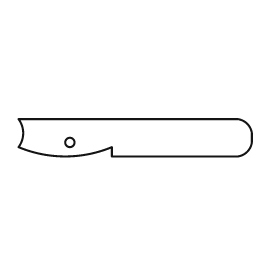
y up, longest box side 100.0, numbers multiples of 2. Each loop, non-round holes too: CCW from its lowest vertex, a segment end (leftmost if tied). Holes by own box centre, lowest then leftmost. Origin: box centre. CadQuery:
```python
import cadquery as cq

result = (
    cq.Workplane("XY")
    .moveTo(-10.0, -8.0)
    .lineTo(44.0, -8.0)
    .threePointArc((48.0, -6.0), (50.0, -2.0))
    .lineTo(50.0, 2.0)
    .threePointArc((48.0, 6.0), (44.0, 8.0))
    .lineTo(-50.0, 8.0)
    .threePointArc((-48.0, 2.0), (-50.0, -4.0))
    .threePointArc((-30.0, -8.0), (-10.0, -4.0))
    .close()
    .moveTo(-28.0, -2.0)
    .circle(2.0)
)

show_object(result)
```